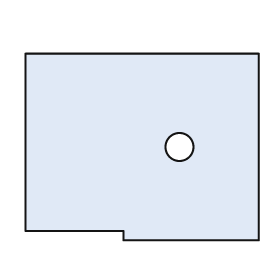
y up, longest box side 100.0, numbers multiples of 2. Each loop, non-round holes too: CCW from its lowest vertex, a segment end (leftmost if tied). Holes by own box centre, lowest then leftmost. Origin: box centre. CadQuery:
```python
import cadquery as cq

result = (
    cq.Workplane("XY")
    .moveTo(-8.0, -40.0)
    .lineTo(50.0, -40.0)
    .lineTo(50.0, 40.0)
    .lineTo(-50.0, 40.0)
    .lineTo(-50.0, -36.0)
    .lineTo(-8.0, -36.0)
    .close()
    .moveTo(16.0, 0.0)
    .circle(6.0)
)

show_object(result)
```